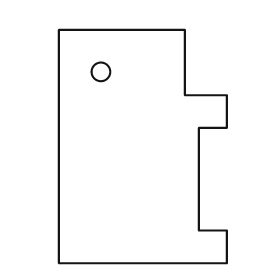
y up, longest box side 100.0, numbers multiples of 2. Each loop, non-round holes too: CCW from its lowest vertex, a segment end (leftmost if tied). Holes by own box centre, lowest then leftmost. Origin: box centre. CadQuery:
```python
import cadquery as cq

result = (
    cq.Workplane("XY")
    .moveTo(-36.0, -50.0)
    .lineTo(36.0, -50.0)
    .lineTo(36.0, -36.0)
    .lineTo(24.0, -36.0)
    .lineTo(24.0, 8.0)
    .lineTo(36.0, 8.0)
    .lineTo(36.0, 22.0)
    .lineTo(18.0, 22.0)
    .lineTo(18.0, 50.0)
    .lineTo(-36.0, 50.0)
    .close()
    .moveTo(-18.0, 32.0)
    .circle(4.0)
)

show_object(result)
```